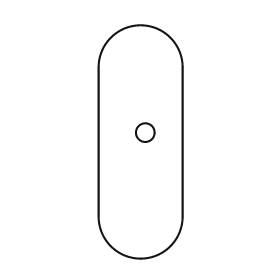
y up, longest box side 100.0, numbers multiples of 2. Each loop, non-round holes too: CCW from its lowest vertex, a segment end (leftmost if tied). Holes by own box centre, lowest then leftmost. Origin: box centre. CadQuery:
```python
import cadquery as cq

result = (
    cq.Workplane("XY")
    .moveTo(-18.0, -32.0)
    .threePointArc((0.0, -50.0), (18.0, -32.0))
    .lineTo(18.0, 32.0)
    .threePointArc((0.0, 50.0), (-18.0, 32.0))
    .close()
    .moveTo(2.0, 4.0)
    .circle(4.0)
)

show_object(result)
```